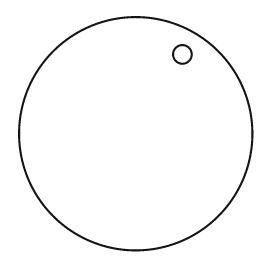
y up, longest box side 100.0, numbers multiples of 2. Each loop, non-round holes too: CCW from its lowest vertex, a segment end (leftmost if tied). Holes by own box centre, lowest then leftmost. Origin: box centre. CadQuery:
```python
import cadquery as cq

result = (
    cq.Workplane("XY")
    .moveTo(0.0, 0.0)
    .circle(50.0)
    .moveTo(20.0, 34.0)
    .circle(4.0)
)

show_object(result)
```